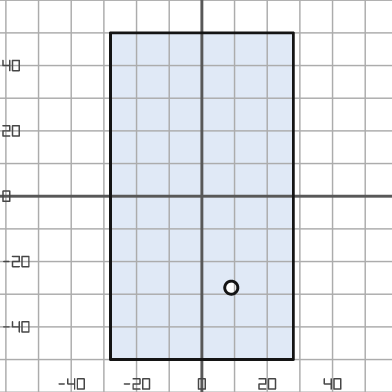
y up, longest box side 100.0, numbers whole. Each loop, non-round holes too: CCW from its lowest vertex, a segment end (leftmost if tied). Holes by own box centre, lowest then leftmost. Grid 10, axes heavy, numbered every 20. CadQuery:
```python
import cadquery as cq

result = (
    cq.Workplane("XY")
    .moveTo(-28.0, -50.0)
    .lineTo(28.0, -50.0)
    .lineTo(28.0, 50.0)
    .lineTo(-28.0, 50.0)
    .close()
    .moveTo(9.0, -28.0)
    .circle(2.0)
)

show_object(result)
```